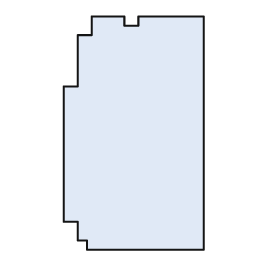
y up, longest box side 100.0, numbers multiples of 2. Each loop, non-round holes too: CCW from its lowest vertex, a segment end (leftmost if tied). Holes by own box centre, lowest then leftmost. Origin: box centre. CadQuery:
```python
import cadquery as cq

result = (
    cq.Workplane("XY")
    .moveTo(-20.0, -50.0)
    .lineTo(30.0, -50.0)
    .lineTo(30.0, 50.0)
    .lineTo(2.0, 50.0)
    .lineTo(2.0, 46.0)
    .lineTo(-4.0, 46.0)
    .lineTo(-4.0, 50.0)
    .lineTo(-18.0, 50.0)
    .lineTo(-18.0, 42.0)
    .lineTo(-24.0, 42.0)
    .lineTo(-24.0, 20.0)
    .lineTo(-30.0, 20.0)
    .lineTo(-30.0, -38.0)
    .lineTo(-24.0, -38.0)
    .lineTo(-24.0, -46.0)
    .lineTo(-20.0, -46.0)
    .close()
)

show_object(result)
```